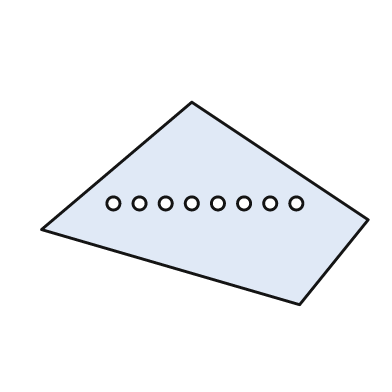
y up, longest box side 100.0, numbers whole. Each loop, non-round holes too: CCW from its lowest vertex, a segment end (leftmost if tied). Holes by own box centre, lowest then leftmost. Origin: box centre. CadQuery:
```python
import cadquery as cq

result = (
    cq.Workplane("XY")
    .moveTo(29.0, -31.0)
    .lineTo(50.0, -5.0)
    .lineTo(-4.0, 31.0)
    .lineTo(-50.0, -8.0)
    .close()
    .moveTo(-28.0, 0.0)
    .circle(2.0)
    .moveTo(-20.0, 0.0)
    .circle(2.0)
    .moveTo(-12.0, 0.0)
    .circle(2.0)
    .moveTo(-4.0, 0.0)
    .circle(2.0)
    .moveTo(4.0, 0.0)
    .circle(2.0)
    .moveTo(12.0, 0.0)
    .circle(2.0)
    .moveTo(20.0, 0.0)
    .circle(2.0)
    .moveTo(28.0, 0.0)
    .circle(2.0)
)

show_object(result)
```